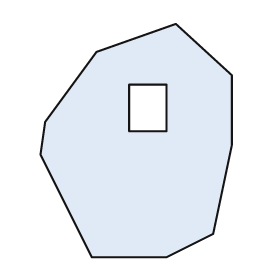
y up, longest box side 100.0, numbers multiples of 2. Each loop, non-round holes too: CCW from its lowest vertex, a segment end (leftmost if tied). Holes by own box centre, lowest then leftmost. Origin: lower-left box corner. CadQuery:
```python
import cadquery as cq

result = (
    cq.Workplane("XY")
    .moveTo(22.0, 0.0)
    .lineTo(54.0, 0.0)
    .lineTo(74.0, 10.0)
    .lineTo(82.0, 48.0)
    .lineTo(82.0, 78.0)
    .lineTo(58.0, 100.0)
    .lineTo(24.0, 88.0)
    .lineTo(2.0, 58.0)
    .lineTo(0.0, 44.0)
    .close()
    .moveTo(38.0, 54.0)
    .lineTo(54.0, 54.0)
    .lineTo(54.0, 74.0)
    .lineTo(38.0, 74.0)
    .close()
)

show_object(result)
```